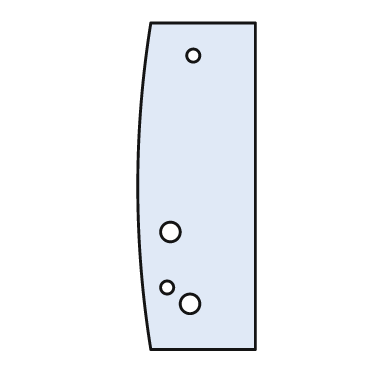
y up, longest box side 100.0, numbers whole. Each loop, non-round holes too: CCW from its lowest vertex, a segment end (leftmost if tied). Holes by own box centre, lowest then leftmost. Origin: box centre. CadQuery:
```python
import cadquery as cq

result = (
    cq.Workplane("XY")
    .moveTo(-14.0, -50.0)
    .lineTo(18.0, -50.0)
    .lineTo(18.0, 50.0)
    .lineTo(-14.0, 50.0)
    .threePointArc((-18.0, 0.0), (-14.0, -50.0))
    .close()
    .moveTo(-2.0, -36.0)
    .circle(3.0)
    .moveTo(-9.0, -31.0)
    .circle(2.0)
    .moveTo(-8.0, -14.0)
    .circle(3.0)
    .moveTo(-1.0, 40.0)
    .circle(2.0)
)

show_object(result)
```